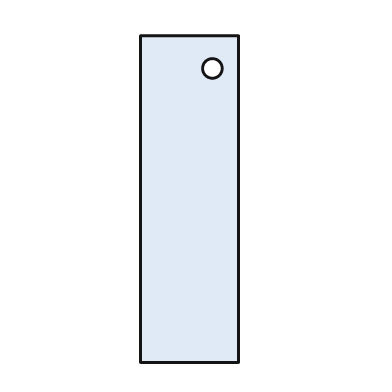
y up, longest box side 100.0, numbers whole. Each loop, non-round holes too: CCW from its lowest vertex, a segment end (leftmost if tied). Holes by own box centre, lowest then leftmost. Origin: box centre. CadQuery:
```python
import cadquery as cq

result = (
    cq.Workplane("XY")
    .moveTo(-15.0, -50.0)
    .lineTo(15.0, -50.0)
    .lineTo(15.0, 50.0)
    .lineTo(-15.0, 50.0)
    .close()
    .moveTo(7.0, 40.0)
    .circle(3.0)
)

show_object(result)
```